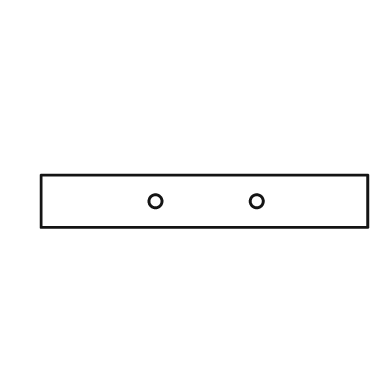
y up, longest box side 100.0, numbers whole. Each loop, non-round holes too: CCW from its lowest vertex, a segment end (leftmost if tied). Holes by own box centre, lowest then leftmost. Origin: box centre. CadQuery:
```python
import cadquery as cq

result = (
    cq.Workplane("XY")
    .moveTo(-50.0, -8.0)
    .lineTo(50.0, -8.0)
    .lineTo(50.0, 8.0)
    .lineTo(-50.0, 8.0)
    .close()
    .moveTo(-15.0, 0.0)
    .circle(2.0)
    .moveTo(16.0, 0.0)
    .circle(2.0)
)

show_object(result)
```